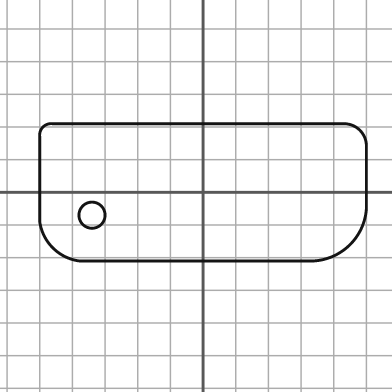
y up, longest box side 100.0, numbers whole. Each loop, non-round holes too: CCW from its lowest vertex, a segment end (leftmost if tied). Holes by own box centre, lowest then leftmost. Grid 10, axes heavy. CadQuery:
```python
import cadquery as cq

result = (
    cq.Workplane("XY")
    .moveTo(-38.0, -21.0)
    .lineTo(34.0, -21.0)
    .threePointArc((45.0, -16.0), (50.0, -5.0))
    .lineTo(50.0, 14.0)
    .threePointArc((48.0, 19.0), (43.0, 21.0))
    .lineTo(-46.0, 21.0)
    .threePointArc((-49.0, 20.0), (-50.0, 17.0))
    .lineTo(-50.0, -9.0)
    .threePointArc((-46.0, -17.0), (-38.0, -21.0))
    .close()
    .moveTo(-34.0, -7.0)
    .circle(4.0)
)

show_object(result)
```